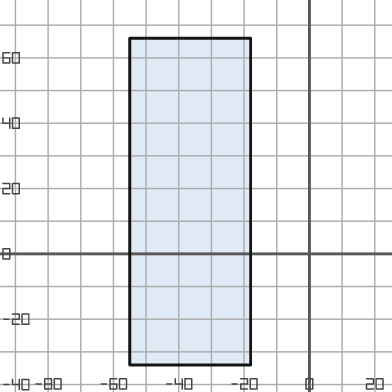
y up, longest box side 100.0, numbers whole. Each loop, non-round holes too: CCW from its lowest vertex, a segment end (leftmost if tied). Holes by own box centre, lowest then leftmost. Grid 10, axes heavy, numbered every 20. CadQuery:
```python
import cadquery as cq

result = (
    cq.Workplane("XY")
    .moveTo(-55.0, -34.0)
    .lineTo(-18.0, -34.0)
    .lineTo(-18.0, 66.0)
    .lineTo(-55.0, 66.0)
    .close()
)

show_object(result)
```